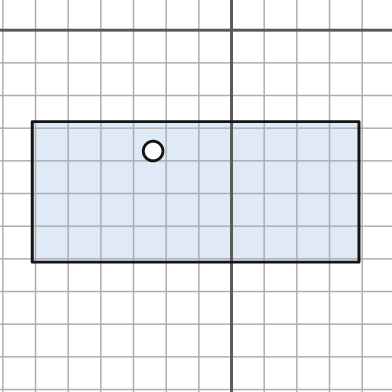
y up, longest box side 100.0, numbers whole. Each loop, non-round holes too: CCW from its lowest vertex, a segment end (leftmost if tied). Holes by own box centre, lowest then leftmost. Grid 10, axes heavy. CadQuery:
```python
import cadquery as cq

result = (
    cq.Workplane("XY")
    .moveTo(-61.0, -71.0)
    .lineTo(39.0, -71.0)
    .lineTo(39.0, -28.0)
    .lineTo(-61.0, -28.0)
    .close()
    .moveTo(-24.0, -37.0)
    .circle(3.0)
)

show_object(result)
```